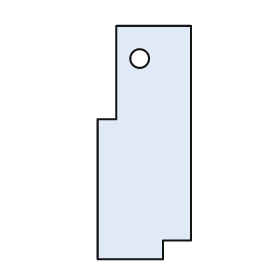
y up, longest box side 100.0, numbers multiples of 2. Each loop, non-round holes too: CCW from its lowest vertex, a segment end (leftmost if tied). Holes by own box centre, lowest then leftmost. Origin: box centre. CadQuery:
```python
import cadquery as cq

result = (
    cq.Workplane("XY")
    .moveTo(-20.0, -50.0)
    .lineTo(8.0, -50.0)
    .lineTo(8.0, -42.0)
    .lineTo(20.0, -42.0)
    .lineTo(20.0, 50.0)
    .lineTo(-12.0, 50.0)
    .lineTo(-12.0, 10.0)
    .lineTo(-20.0, 10.0)
    .close()
    .moveTo(-2.0, 36.0)
    .circle(4.0)
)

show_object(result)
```